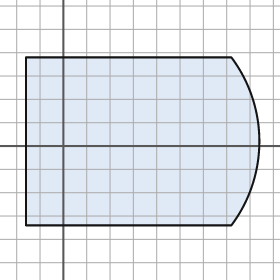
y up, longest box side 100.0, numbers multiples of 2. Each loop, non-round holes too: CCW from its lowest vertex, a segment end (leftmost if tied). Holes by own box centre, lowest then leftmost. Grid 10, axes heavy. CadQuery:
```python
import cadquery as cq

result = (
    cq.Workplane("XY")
    .moveTo(-16.0, -34.0)
    .lineTo(72.0, -34.0)
    .threePointArc((84.0, 2.0), (72.0, 38.0))
    .lineTo(-16.0, 38.0)
    .close()
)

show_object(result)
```